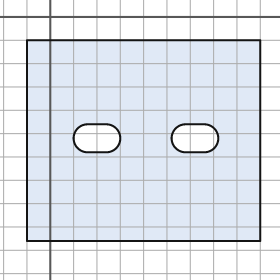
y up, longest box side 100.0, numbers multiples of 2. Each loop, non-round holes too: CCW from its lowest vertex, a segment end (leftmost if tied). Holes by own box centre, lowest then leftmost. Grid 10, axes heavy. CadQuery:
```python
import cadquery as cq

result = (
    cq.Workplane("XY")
    .moveTo(-10.0, -96.0)
    .lineTo(90.0, -96.0)
    .lineTo(90.0, -10.0)
    .lineTo(-10.0, -10.0)
    .close()
    .moveTo(16.0, -58.0)
    .lineTo(24.0, -58.0)
    .threePointArc((30.0, -52.0), (24.0, -46.0))
    .lineTo(16.0, -46.0)
    .threePointArc((10.0, -52.0), (16.0, -58.0))
    .close()
    .moveTo(58.0, -58.0)
    .lineTo(66.0, -58.0)
    .threePointArc((72.0, -52.0), (66.0, -46.0))
    .lineTo(58.0, -46.0)
    .threePointArc((52.0, -52.0), (58.0, -58.0))
    .close()
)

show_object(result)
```